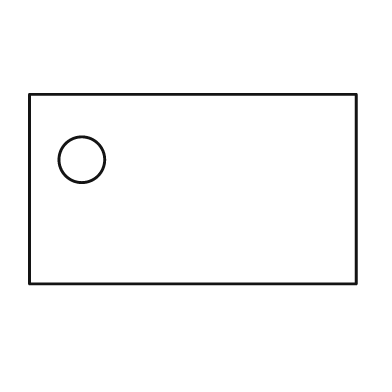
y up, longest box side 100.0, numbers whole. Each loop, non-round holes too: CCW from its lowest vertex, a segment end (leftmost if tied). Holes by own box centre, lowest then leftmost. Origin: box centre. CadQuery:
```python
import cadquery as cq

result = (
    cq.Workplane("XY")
    .moveTo(-50.0, -29.0)
    .lineTo(50.0, -29.0)
    .lineTo(50.0, 29.0)
    .lineTo(-50.0, 29.0)
    .close()
    .moveTo(-34.0, 9.0)
    .circle(7.0)
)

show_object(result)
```